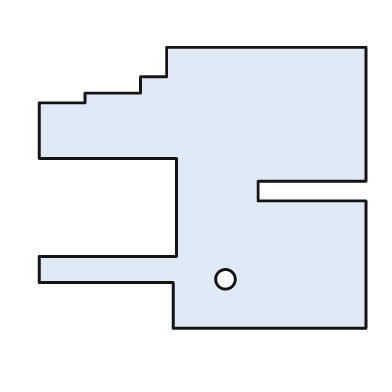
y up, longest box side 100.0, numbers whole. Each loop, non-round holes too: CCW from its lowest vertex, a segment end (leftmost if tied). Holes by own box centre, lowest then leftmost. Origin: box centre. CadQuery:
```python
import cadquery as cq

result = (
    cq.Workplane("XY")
    .moveTo(-9.0, -43.0)
    .lineTo(50.0, -43.0)
    .lineTo(50.0, -4.0)
    .lineTo(17.0, -4.0)
    .lineTo(17.0, 2.0)
    .lineTo(50.0, 2.0)
    .lineTo(50.0, 43.0)
    .lineTo(-11.0, 43.0)
    .lineTo(-11.0, 34.0)
    .lineTo(-19.0, 34.0)
    .lineTo(-19.0, 29.0)
    .lineTo(-36.0, 29.0)
    .lineTo(-36.0, 26.0)
    .lineTo(-50.0, 26.0)
    .lineTo(-50.0, 9.0)
    .lineTo(-8.0, 9.0)
    .lineTo(-8.0, -21.0)
    .lineTo(-50.0, -21.0)
    .lineTo(-50.0, -29.0)
    .lineTo(-9.0, -29.0)
    .close()
    .moveTo(7.0, -28.0)
    .circle(3.0)
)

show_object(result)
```